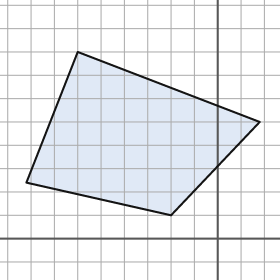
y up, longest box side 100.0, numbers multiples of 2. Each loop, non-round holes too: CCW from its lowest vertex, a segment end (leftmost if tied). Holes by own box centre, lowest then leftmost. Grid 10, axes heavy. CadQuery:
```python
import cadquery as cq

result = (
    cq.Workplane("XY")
    .moveTo(-20.0, 10.0)
    .lineTo(18.0, 50.0)
    .lineTo(-60.0, 80.0)
    .lineTo(-82.0, 24.0)
    .close()
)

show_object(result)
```